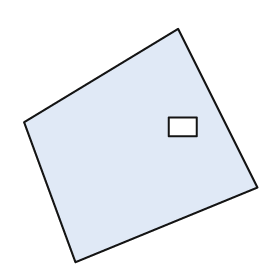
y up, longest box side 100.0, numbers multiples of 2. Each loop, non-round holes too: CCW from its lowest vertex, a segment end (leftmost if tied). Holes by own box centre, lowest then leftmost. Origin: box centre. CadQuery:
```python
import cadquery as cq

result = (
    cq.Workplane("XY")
    .moveTo(-28.0, -50.0)
    .lineTo(50.0, -18.0)
    .lineTo(16.0, 50.0)
    .lineTo(-50.0, 10.0)
    .close()
    .moveTo(12.0, 4.0)
    .lineTo(24.0, 4.0)
    .lineTo(24.0, 12.0)
    .lineTo(12.0, 12.0)
    .close()
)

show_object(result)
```